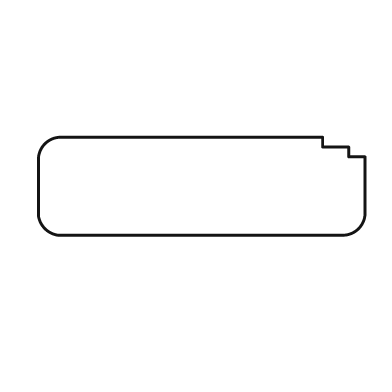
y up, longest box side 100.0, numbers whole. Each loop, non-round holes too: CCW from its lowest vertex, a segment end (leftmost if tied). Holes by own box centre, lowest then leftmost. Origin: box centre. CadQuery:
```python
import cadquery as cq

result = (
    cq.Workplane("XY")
    .moveTo(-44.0, -15.0)
    .lineTo(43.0, -15.0)
    .threePointArc((48.0, -13.0), (50.0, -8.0))
    .lineTo(50.0, 9.0)
    .lineTo(45.0, 9.0)
    .lineTo(45.0, 12.0)
    .lineTo(37.0, 12.0)
    .lineTo(37.0, 15.0)
    .lineTo(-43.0, 15.0)
    .threePointArc((-48.0, 13.0), (-50.0, 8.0))
    .lineTo(-50.0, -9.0)
    .threePointArc((-48.0, -13.0), (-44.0, -15.0))
    .close()
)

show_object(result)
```